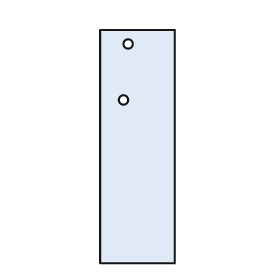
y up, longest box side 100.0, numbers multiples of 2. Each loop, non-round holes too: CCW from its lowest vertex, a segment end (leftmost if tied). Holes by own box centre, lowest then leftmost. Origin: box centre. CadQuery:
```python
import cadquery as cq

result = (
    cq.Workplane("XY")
    .moveTo(-16.0, -50.0)
    .lineTo(16.0, -50.0)
    .lineTo(16.0, 50.0)
    .lineTo(-16.0, 50.0)
    .close()
    .moveTo(-6.0, 20.0)
    .circle(2.0)
    .moveTo(-4.0, 44.0)
    .circle(2.0)
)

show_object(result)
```